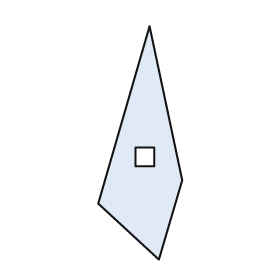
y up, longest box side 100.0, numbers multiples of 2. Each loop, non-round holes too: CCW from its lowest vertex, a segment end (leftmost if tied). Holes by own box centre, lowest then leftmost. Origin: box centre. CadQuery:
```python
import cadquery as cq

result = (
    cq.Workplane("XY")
    .moveTo(8.0, -50.0)
    .lineTo(18.0, -16.0)
    .lineTo(4.0, 50.0)
    .lineTo(-18.0, -26.0)
    .close()
    .moveTo(-2.0, -10.0)
    .lineTo(6.0, -10.0)
    .lineTo(6.0, -2.0)
    .lineTo(-2.0, -2.0)
    .close()
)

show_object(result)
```